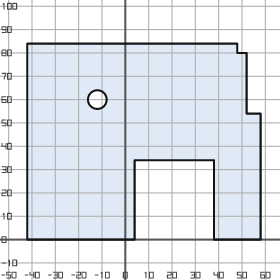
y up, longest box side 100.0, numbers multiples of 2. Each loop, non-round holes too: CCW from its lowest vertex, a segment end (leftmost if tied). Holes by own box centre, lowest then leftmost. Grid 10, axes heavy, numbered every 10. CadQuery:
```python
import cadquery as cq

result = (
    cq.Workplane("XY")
    .moveTo(-42.0, 0.0)
    .lineTo(4.0, 0.0)
    .lineTo(4.0, 34.0)
    .lineTo(38.0, 34.0)
    .lineTo(38.0, 0.0)
    .lineTo(58.0, 0.0)
    .lineTo(58.0, 54.0)
    .lineTo(52.0, 54.0)
    .lineTo(52.0, 80.0)
    .lineTo(48.0, 80.0)
    .lineTo(48.0, 84.0)
    .lineTo(-42.0, 84.0)
    .close()
    .moveTo(-12.0, 60.0)
    .circle(4.0)
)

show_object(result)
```